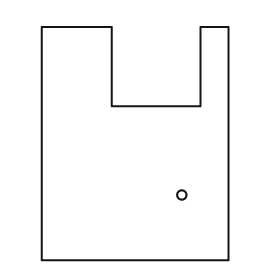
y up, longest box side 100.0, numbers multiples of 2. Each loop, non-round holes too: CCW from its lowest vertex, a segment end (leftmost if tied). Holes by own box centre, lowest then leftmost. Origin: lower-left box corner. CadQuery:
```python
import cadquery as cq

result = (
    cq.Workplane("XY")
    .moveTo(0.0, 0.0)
    .lineTo(80.0, 0.0)
    .lineTo(80.0, 100.0)
    .lineTo(68.0, 100.0)
    .lineTo(68.0, 66.0)
    .lineTo(30.0, 66.0)
    .lineTo(30.0, 100.0)
    .lineTo(0.0, 100.0)
    .close()
    .moveTo(60.0, 28.0)
    .circle(2.0)
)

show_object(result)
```